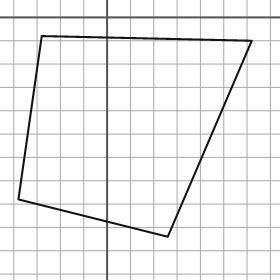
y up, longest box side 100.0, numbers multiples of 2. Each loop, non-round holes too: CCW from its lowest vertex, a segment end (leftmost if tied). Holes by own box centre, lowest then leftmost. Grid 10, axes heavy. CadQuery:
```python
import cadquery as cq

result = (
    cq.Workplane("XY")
    .moveTo(26.0, -94.0)
    .lineTo(62.0, -10.0)
    .lineTo(-28.0, -8.0)
    .lineTo(-38.0, -78.0)
    .close()
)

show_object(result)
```